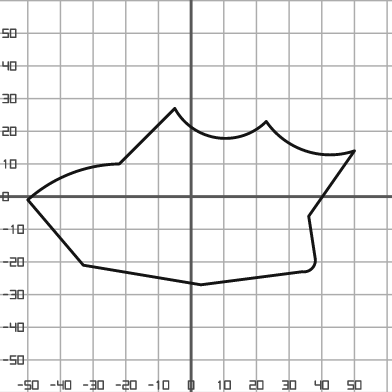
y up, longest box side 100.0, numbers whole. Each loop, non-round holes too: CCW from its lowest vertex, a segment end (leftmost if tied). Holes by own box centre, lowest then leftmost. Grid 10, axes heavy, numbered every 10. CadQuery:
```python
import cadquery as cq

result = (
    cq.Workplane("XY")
    .moveTo(3.0, -27.0)
    .lineTo(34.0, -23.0)
    .threePointArc((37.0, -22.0), (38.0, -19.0))
    .lineTo(36.0, -6.0)
    .lineTo(50.0, 14.0)
    .threePointArc((35.0, 14.0), (23.0, 23.0))
    .threePointArc((8.0, 18.0), (-5.0, 27.0))
    .lineTo(-22.0, 10.0)
    .threePointArc((-37.0, 7.0), (-50.0, -1.0))
    .lineTo(-33.0, -21.0)
    .close()
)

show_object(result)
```